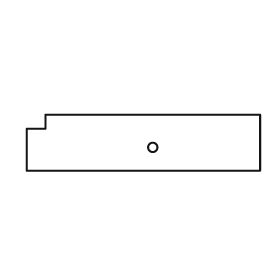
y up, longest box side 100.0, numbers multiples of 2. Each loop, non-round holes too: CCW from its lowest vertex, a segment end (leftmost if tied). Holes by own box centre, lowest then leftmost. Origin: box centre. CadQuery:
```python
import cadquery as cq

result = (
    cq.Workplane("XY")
    .moveTo(-50.0, -12.0)
    .lineTo(50.0, -12.0)
    .lineTo(50.0, 12.0)
    .lineTo(-42.0, 12.0)
    .lineTo(-42.0, 6.0)
    .lineTo(-50.0, 6.0)
    .close()
    .moveTo(4.0, -2.0)
    .circle(2.0)
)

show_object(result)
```